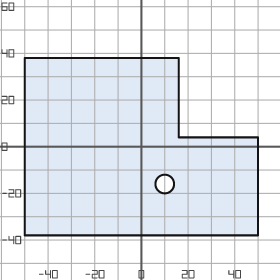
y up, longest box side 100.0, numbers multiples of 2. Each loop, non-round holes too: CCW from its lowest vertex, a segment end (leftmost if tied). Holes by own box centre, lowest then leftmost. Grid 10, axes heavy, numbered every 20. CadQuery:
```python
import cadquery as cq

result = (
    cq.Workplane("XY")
    .moveTo(-50.0, -38.0)
    .lineTo(50.0, -38.0)
    .lineTo(50.0, 4.0)
    .lineTo(16.0, 4.0)
    .lineTo(16.0, 38.0)
    .lineTo(-50.0, 38.0)
    .close()
    .moveTo(10.0, -16.0)
    .circle(4.0)
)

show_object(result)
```